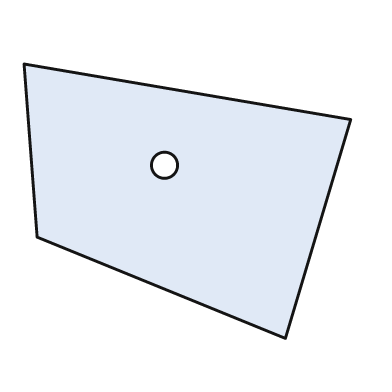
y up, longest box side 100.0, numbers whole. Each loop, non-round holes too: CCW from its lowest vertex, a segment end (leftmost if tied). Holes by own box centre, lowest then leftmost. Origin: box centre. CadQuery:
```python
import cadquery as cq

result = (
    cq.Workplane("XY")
    .moveTo(30.0, -42.0)
    .lineTo(50.0, 25.0)
    .lineTo(-50.0, 42.0)
    .lineTo(-46.0, -11.0)
    .close()
    .moveTo(-7.0, 11.0)
    .circle(4.0)
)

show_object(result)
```